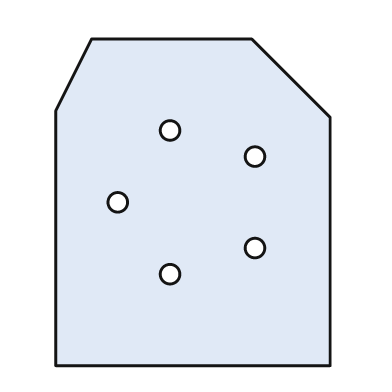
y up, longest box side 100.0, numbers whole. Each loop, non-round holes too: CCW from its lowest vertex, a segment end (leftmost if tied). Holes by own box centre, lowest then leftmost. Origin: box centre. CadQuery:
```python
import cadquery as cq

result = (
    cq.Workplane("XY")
    .moveTo(-42.0, -50.0)
    .lineTo(42.0, -50.0)
    .lineTo(42.0, 26.0)
    .lineTo(18.0, 50.0)
    .lineTo(-31.0, 50.0)
    .lineTo(-42.0, 28.0)
    .close()
    .moveTo(-7.0, -22.0)
    .circle(3.0)
    .moveTo(19.0, -14.0)
    .circle(3.0)
    .moveTo(-23.0, 0.0)
    .circle(3.0)
    .moveTo(19.0, 14.0)
    .circle(3.0)
    .moveTo(-7.0, 22.0)
    .circle(3.0)
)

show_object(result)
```